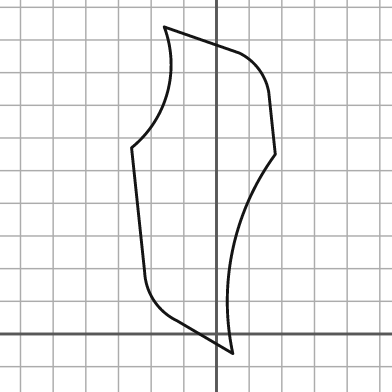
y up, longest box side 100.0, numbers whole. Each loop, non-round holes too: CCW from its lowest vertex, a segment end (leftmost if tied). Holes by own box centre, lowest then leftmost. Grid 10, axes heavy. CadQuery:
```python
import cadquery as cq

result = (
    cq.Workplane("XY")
    .moveTo(5.0, -6.0)
    .threePointArc((5.0, 26.0), (18.0, 55.0))
    .lineTo(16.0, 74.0)
    .threePointArc((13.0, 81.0), (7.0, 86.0))
    .lineTo(-16.0, 94.0)
    .threePointArc((-15.0, 74.0), (-26.0, 57.0))
    .lineTo(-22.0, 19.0)
    .threePointArc((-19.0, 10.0), (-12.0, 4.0))
    .close()
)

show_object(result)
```